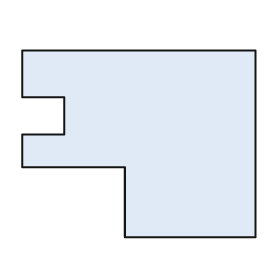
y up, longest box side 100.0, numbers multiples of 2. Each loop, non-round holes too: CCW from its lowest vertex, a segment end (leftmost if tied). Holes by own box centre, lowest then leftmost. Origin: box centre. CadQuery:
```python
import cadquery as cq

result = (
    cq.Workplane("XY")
    .moveTo(-6.0, -40.0)
    .lineTo(50.0, -40.0)
    .lineTo(50.0, 40.0)
    .lineTo(-50.0, 40.0)
    .lineTo(-50.0, 20.0)
    .lineTo(-32.0, 20.0)
    .lineTo(-32.0, 4.0)
    .lineTo(-50.0, 4.0)
    .lineTo(-50.0, -10.0)
    .lineTo(-6.0, -10.0)
    .close()
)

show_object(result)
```